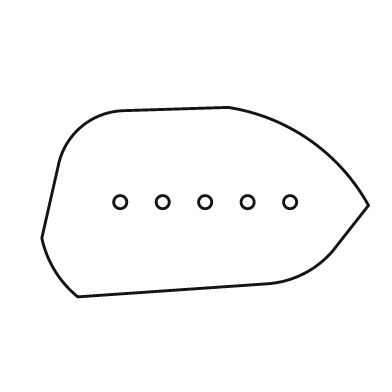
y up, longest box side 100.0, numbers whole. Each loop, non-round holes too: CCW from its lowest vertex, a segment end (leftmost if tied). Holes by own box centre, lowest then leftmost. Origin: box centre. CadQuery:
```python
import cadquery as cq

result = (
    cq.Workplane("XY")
    .moveTo(-39.0, -29.0)
    .lineTo(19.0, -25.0)
    .threePointArc((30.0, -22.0), (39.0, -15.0))
    .lineTo(50.0, -1.0)
    .threePointArc((32.0, 19.0), (7.0, 29.0))
    .lineTo(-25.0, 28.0)
    .threePointArc((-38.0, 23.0), (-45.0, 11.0))
    .lineTo(-50.0, -11.0)
    .threePointArc((-46.0, -21.0), (-39.0, -29.0))
    .close()
    .moveTo(-26.0, 0.0)
    .circle(2.0)
    .moveTo(-13.0, 0.0)
    .circle(2.0)
    .moveTo(0.0, 0.0)
    .circle(2.0)
    .moveTo(13.0, 0.0)
    .circle(2.0)
    .moveTo(26.0, 0.0)
    .circle(2.0)
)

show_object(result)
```